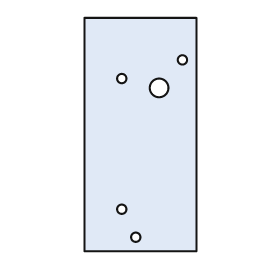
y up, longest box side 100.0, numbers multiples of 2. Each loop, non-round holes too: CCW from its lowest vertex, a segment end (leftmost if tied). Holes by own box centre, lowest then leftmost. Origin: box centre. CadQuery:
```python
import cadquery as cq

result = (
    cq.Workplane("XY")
    .moveTo(-24.0, -50.0)
    .lineTo(24.0, -50.0)
    .lineTo(24.0, 50.0)
    .lineTo(-24.0, 50.0)
    .close()
    .moveTo(-2.0, -44.0)
    .circle(2.0)
    .moveTo(-8.0, -32.0)
    .circle(2.0)
    .moveTo(8.0, 20.0)
    .circle(4.0)
    .moveTo(-8.0, 24.0)
    .circle(2.0)
    .moveTo(18.0, 32.0)
    .circle(2.0)
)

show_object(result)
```